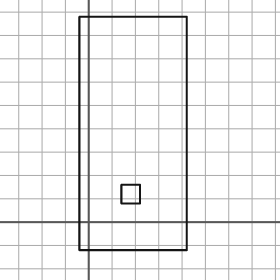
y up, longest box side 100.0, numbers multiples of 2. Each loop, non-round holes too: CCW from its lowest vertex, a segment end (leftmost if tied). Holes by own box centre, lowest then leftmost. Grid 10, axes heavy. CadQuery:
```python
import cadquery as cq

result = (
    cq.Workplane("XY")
    .moveTo(-4.0, -12.0)
    .lineTo(42.0, -12.0)
    .lineTo(42.0, 88.0)
    .lineTo(-4.0, 88.0)
    .close()
    .moveTo(14.0, 8.0)
    .lineTo(22.0, 8.0)
    .lineTo(22.0, 16.0)
    .lineTo(14.0, 16.0)
    .close()
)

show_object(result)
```